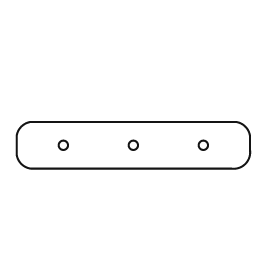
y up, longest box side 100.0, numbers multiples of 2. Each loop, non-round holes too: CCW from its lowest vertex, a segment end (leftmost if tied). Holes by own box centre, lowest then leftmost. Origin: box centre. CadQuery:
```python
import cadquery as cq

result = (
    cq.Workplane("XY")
    .moveTo(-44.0, -10.0)
    .lineTo(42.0, -10.0)
    .threePointArc((48.0, -8.0), (50.0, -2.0))
    .lineTo(50.0, 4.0)
    .threePointArc((48.0, 8.0), (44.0, 10.0))
    .lineTo(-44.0, 10.0)
    .threePointArc((-48.0, 8.0), (-50.0, 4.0))
    .lineTo(-50.0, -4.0)
    .threePointArc((-48.0, -8.0), (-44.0, -10.0))
    .close()
    .moveTo(-30.0, 0.0)
    .circle(2.0)
    .moveTo(0.0, 0.0)
    .circle(2.0)
    .moveTo(30.0, 0.0)
    .circle(2.0)
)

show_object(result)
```